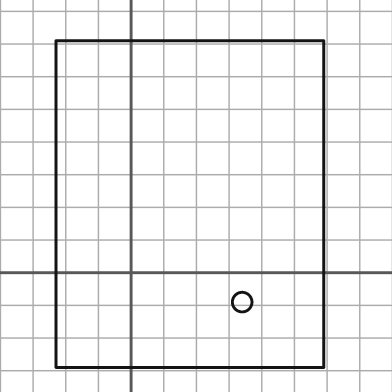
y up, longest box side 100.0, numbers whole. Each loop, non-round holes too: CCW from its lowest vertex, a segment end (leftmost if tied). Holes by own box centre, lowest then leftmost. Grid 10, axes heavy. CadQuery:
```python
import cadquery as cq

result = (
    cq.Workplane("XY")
    .moveTo(-23.0, -29.0)
    .lineTo(59.0, -29.0)
    .lineTo(59.0, 71.0)
    .lineTo(-23.0, 71.0)
    .close()
    .moveTo(34.0, -9.0)
    .circle(3.0)
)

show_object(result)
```